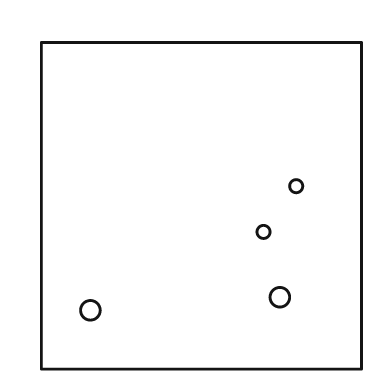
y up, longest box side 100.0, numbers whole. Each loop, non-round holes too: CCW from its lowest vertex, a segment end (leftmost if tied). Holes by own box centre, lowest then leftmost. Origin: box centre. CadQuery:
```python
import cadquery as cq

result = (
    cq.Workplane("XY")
    .moveTo(-49.0, -50.0)
    .lineTo(49.0, -50.0)
    .lineTo(49.0, 50.0)
    .lineTo(-49.0, 50.0)
    .close()
    .moveTo(-34.0, -32.0)
    .circle(3.0)
    .moveTo(24.0, -28.0)
    .circle(3.0)
    .moveTo(19.0, -8.0)
    .circle(2.0)
    .moveTo(29.0, 6.0)
    .circle(2.0)
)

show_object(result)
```